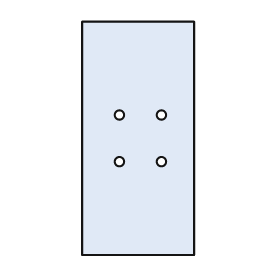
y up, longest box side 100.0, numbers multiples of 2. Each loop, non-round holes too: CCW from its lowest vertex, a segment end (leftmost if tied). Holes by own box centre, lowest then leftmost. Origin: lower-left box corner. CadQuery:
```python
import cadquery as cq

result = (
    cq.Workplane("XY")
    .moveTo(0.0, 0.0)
    .lineTo(48.0, 0.0)
    .lineTo(48.0, 100.0)
    .lineTo(0.0, 100.0)
    .close()
    .moveTo(16.0, 40.0)
    .circle(2.0)
    .moveTo(34.0, 40.0)
    .circle(2.0)
    .moveTo(16.0, 60.0)
    .circle(2.0)
    .moveTo(34.0, 60.0)
    .circle(2.0)
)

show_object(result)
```